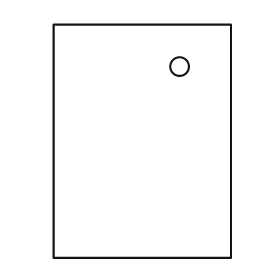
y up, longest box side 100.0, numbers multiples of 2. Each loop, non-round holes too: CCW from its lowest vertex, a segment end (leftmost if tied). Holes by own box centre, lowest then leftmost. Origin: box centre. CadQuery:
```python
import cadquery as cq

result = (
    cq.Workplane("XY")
    .moveTo(-38.0, -50.0)
    .lineTo(38.0, -50.0)
    .lineTo(38.0, 50.0)
    .lineTo(-38.0, 50.0)
    .close()
    .moveTo(16.0, 32.0)
    .circle(4.0)
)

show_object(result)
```